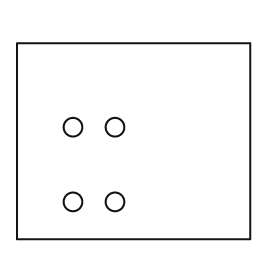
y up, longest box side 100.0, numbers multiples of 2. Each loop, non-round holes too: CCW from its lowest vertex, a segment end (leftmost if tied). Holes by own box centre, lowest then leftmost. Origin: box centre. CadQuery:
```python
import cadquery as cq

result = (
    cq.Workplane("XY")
    .moveTo(-50.0, -42.0)
    .lineTo(50.0, -42.0)
    .lineTo(50.0, 42.0)
    .lineTo(-50.0, 42.0)
    .close()
    .moveTo(-26.0, -26.0)
    .circle(4.0)
    .moveTo(-8.0, -26.0)
    .circle(4.0)
    .moveTo(-26.0, 6.0)
    .circle(4.0)
    .moveTo(-8.0, 6.0)
    .circle(4.0)
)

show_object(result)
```